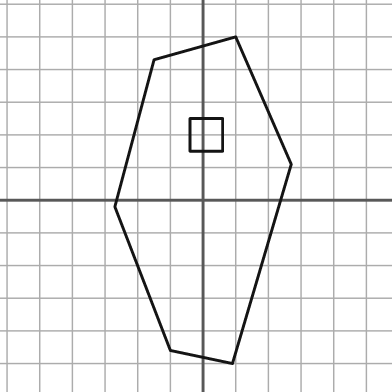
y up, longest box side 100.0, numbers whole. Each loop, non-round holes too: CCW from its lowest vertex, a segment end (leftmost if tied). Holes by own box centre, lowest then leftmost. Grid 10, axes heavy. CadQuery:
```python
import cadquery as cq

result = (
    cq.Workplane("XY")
    .moveTo(9.0, -50.0)
    .lineTo(27.0, 11.0)
    .lineTo(10.0, 50.0)
    .lineTo(-15.0, 43.0)
    .lineTo(-27.0, -2.0)
    .lineTo(-10.0, -46.0)
    .close()
    .moveTo(-4.0, 15.0)
    .lineTo(6.0, 15.0)
    .lineTo(6.0, 25.0)
    .lineTo(-4.0, 25.0)
    .close()
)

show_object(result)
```